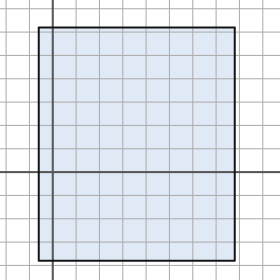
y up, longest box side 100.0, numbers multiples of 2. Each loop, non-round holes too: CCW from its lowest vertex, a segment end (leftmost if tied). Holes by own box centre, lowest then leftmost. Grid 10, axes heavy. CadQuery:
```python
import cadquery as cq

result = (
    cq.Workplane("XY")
    .moveTo(-6.0, -38.0)
    .lineTo(78.0, -38.0)
    .lineTo(78.0, 62.0)
    .lineTo(-6.0, 62.0)
    .close()
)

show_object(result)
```